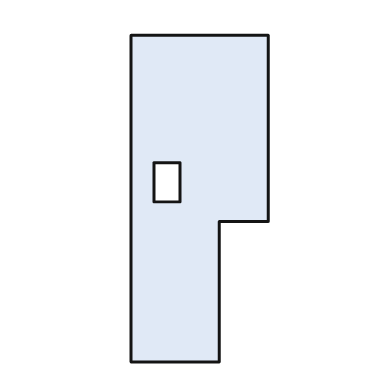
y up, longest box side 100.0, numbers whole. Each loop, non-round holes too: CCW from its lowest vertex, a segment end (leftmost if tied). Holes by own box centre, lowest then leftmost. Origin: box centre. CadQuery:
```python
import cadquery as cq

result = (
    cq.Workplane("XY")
    .moveTo(-21.0, -50.0)
    .lineTo(6.0, -50.0)
    .lineTo(6.0, -7.0)
    .lineTo(21.0, -7.0)
    .lineTo(21.0, 50.0)
    .lineTo(-21.0, 50.0)
    .close()
    .moveTo(-14.0, -1.0)
    .lineTo(-6.0, -1.0)
    .lineTo(-6.0, 11.0)
    .lineTo(-14.0, 11.0)
    .close()
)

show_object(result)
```